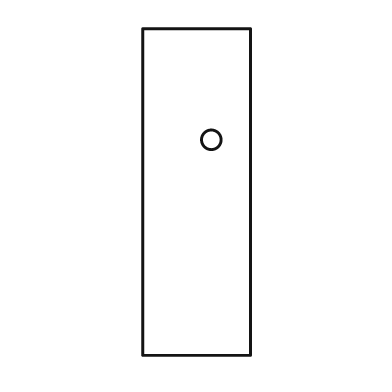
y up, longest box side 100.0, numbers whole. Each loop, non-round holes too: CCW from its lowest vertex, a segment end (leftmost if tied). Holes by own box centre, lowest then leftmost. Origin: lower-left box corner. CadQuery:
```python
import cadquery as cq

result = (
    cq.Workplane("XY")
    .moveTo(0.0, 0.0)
    .lineTo(33.0, 0.0)
    .lineTo(33.0, 100.0)
    .lineTo(0.0, 100.0)
    .close()
    .moveTo(21.0, 66.0)
    .circle(3.0)
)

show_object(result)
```